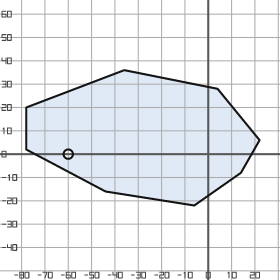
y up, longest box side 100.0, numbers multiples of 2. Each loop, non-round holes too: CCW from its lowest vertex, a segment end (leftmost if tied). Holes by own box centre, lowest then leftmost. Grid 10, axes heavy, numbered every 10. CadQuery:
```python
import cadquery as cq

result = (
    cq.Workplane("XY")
    .moveTo(-6.0, -22.0)
    .lineTo(14.0, -8.0)
    .lineTo(22.0, 6.0)
    .lineTo(4.0, 28.0)
    .lineTo(-36.0, 36.0)
    .lineTo(-78.0, 20.0)
    .lineTo(-78.0, 2.0)
    .lineTo(-44.0, -16.0)
    .close()
    .moveTo(-60.0, 0.0)
    .circle(2.0)
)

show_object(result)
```